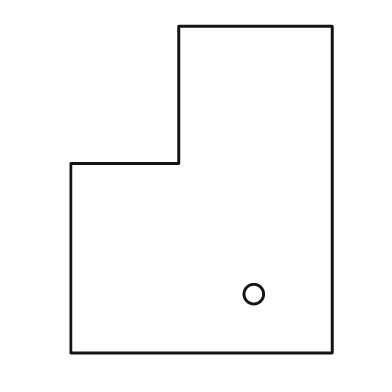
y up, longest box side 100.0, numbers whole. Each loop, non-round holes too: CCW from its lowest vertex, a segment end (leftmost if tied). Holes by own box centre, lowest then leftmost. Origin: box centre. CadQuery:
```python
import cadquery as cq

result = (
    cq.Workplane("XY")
    .moveTo(-40.0, -50.0)
    .lineTo(40.0, -50.0)
    .lineTo(40.0, 50.0)
    .lineTo(-7.0, 50.0)
    .lineTo(-7.0, 8.0)
    .lineTo(-40.0, 8.0)
    .close()
    .moveTo(16.0, -32.0)
    .circle(3.0)
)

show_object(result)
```